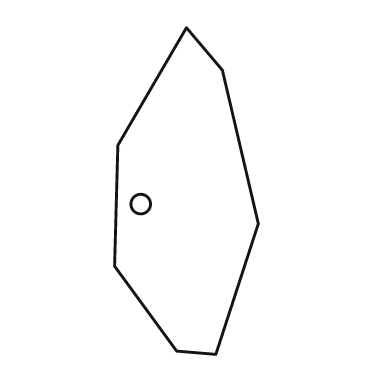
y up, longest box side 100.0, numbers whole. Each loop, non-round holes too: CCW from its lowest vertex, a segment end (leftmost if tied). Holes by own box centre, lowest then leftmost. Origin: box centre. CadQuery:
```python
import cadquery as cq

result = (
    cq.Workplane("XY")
    .moveTo(9.0, -50.0)
    .lineTo(22.0, -10.0)
    .lineTo(11.0, 37.0)
    .lineTo(0.0, 50.0)
    .lineTo(-21.0, 14.0)
    .lineTo(-22.0, -23.0)
    .lineTo(-3.0, -49.0)
    .close()
    .moveTo(-14.0, -4.0)
    .circle(3.0)
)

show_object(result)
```